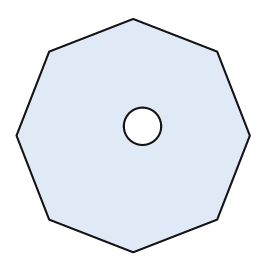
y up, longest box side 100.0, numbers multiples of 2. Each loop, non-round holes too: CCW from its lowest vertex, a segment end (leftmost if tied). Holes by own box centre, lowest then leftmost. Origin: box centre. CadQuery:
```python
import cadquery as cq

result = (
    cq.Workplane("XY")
    .moveTo(0.0, -50.0)
    .lineTo(36.0, -36.0)
    .lineTo(50.0, 0.0)
    .lineTo(36.0, 36.0)
    .lineTo(0.0, 50.0)
    .lineTo(-36.0, 36.0)
    .lineTo(-50.0, 0.0)
    .lineTo(-36.0, -36.0)
    .close()
    .moveTo(4.0, 4.0)
    .circle(8.0)
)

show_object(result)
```